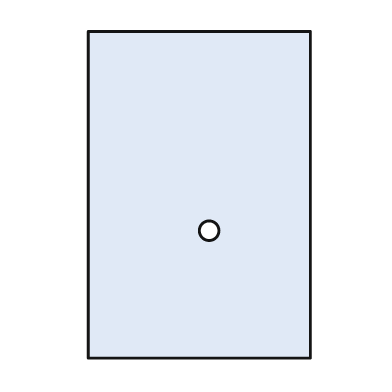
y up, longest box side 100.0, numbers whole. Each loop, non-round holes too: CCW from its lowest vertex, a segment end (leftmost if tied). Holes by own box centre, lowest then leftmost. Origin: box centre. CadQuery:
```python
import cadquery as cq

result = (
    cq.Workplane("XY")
    .moveTo(-34.0, -50.0)
    .lineTo(34.0, -50.0)
    .lineTo(34.0, 50.0)
    .lineTo(-34.0, 50.0)
    .close()
    .moveTo(3.0, -11.0)
    .circle(3.0)
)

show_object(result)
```